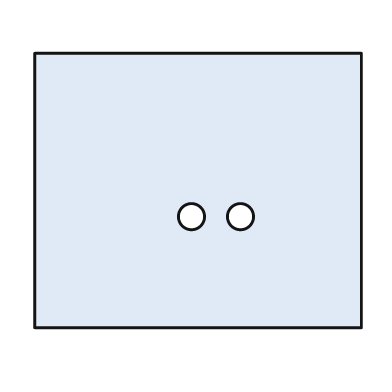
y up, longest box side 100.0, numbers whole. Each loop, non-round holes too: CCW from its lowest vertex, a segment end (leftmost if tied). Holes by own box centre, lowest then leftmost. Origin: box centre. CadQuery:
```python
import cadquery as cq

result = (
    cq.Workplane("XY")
    .moveTo(-50.0, -42.0)
    .lineTo(50.0, -42.0)
    .lineTo(50.0, 42.0)
    .lineTo(-50.0, 42.0)
    .close()
    .moveTo(-2.0, -8.0)
    .circle(4.0)
    .moveTo(13.0, -8.0)
    .circle(4.0)
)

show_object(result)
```